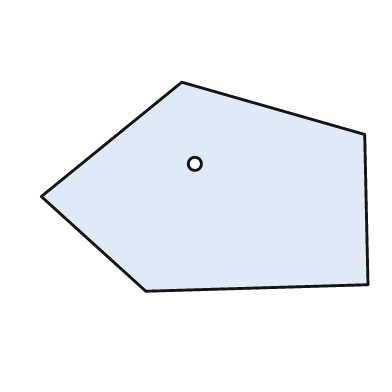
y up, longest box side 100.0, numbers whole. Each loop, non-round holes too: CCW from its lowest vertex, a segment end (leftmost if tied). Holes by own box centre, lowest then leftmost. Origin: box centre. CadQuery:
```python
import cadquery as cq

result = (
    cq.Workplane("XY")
    .moveTo(-18.0, -32.0)
    .lineTo(50.0, -30.0)
    .lineTo(49.0, 16.0)
    .lineTo(-7.0, 32.0)
    .lineTo(-50.0, -3.0)
    .close()
    .moveTo(-3.0, 7.0)
    .circle(2.0)
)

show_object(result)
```